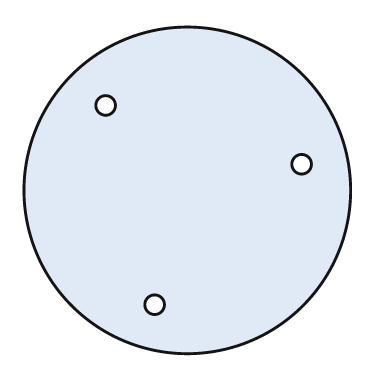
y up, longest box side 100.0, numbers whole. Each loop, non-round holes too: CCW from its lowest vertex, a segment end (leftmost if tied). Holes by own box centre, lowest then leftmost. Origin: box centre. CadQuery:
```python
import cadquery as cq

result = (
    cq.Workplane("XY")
    .moveTo(0.0, 0.0)
    .circle(50.0)
    .moveTo(-10.0, -35.0)
    .circle(3.0)
    .moveTo(35.0, 8.0)
    .circle(3.0)
    .moveTo(-25.0, 26.0)
    .circle(3.0)
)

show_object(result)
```